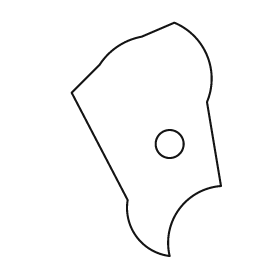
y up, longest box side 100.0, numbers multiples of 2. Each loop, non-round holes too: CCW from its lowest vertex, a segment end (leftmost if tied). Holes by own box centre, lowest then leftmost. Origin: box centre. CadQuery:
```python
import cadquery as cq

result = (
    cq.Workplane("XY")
    .moveTo(10.0, -50.0)
    .threePointArc((14.0, -30.0), (32.0, -20.0))
    .lineTo(26.0, 16.0)
    .threePointArc((26.0, 36.0), (12.0, 50.0))
    .lineTo(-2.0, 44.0)
    .threePointArc((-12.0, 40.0), (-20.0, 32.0))
    .lineTo(-32.0, 20.0)
    .lineTo(-8.0, -26.0)
    .threePointArc((-4.0, -42.0), (10.0, -50.0))
    .close()
    .moveTo(10.0, -2.0)
    .circle(6.0)
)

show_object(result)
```